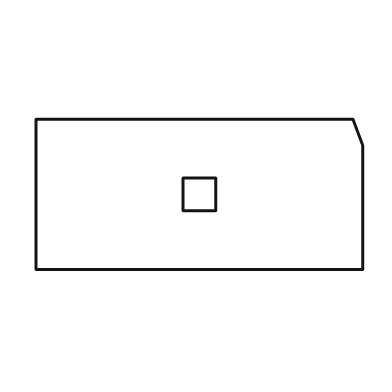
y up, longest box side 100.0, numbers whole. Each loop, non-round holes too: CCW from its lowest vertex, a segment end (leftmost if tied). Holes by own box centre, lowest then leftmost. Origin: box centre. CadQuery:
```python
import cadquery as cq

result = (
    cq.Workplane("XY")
    .moveTo(-50.0, -23.0)
    .lineTo(50.0, -23.0)
    .lineTo(50.0, 15.0)
    .lineTo(47.0, 23.0)
    .lineTo(-50.0, 23.0)
    .close()
    .moveTo(-5.0, -5.0)
    .lineTo(5.0, -5.0)
    .lineTo(5.0, 5.0)
    .lineTo(-5.0, 5.0)
    .close()
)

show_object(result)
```